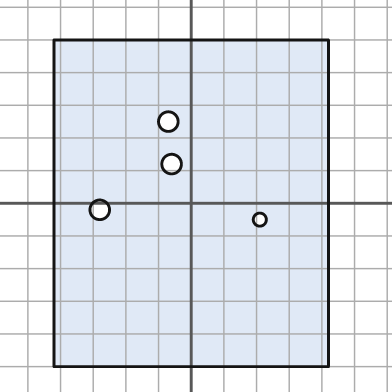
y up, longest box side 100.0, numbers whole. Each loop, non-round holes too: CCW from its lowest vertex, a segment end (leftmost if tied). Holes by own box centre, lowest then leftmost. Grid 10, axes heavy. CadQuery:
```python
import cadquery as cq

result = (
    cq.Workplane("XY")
    .moveTo(-42.0, -50.0)
    .lineTo(42.0, -50.0)
    .lineTo(42.0, 50.0)
    .lineTo(-42.0, 50.0)
    .close()
    .moveTo(21.0, -5.0)
    .circle(2.0)
    .moveTo(-28.0, -2.0)
    .circle(3.0)
    .moveTo(-6.0, 12.0)
    .circle(3.0)
    .moveTo(-7.0, 25.0)
    .circle(3.0)
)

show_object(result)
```